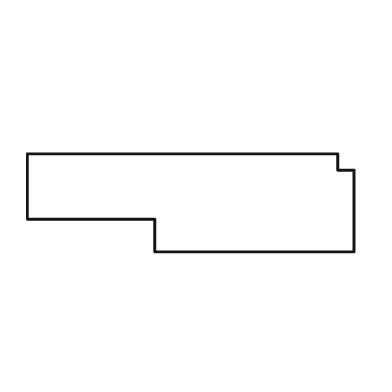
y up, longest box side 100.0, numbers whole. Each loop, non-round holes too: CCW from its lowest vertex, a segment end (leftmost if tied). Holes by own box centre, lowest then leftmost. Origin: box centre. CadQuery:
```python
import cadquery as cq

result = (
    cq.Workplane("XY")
    .moveTo(-11.0, -15.0)
    .lineTo(50.0, -15.0)
    .lineTo(50.0, 10.0)
    .lineTo(45.0, 10.0)
    .lineTo(45.0, 15.0)
    .lineTo(-50.0, 15.0)
    .lineTo(-50.0, -5.0)
    .lineTo(-11.0, -5.0)
    .close()
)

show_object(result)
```